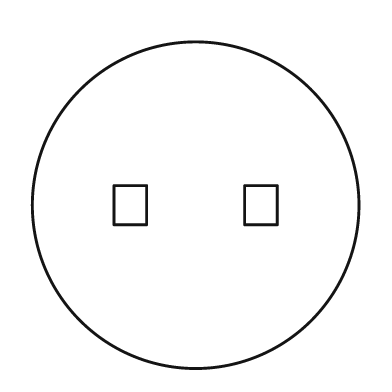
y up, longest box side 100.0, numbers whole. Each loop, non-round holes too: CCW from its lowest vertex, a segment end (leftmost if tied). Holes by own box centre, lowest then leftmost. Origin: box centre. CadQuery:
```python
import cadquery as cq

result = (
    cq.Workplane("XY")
    .moveTo(0.0, 0.0)
    .circle(50.0)
    .moveTo(-25.0, -6.0)
    .lineTo(-15.0, -6.0)
    .lineTo(-15.0, 6.0)
    .lineTo(-25.0, 6.0)
    .close()
    .moveTo(15.0, -6.0)
    .lineTo(25.0, -6.0)
    .lineTo(25.0, 6.0)
    .lineTo(15.0, 6.0)
    .close()
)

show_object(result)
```